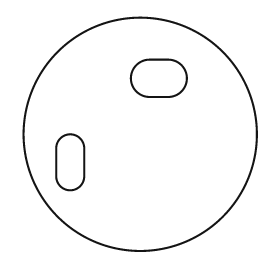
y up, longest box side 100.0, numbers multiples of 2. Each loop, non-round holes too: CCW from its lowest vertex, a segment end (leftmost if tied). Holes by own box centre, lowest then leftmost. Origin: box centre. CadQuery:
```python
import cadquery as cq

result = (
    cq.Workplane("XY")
    .moveTo(0.0, 0.0)
    .circle(50.0)
    .moveTo(-36.0, -18.0)
    .threePointArc((-30.0, -24.0), (-24.0, -18.0))
    .lineTo(-24.0, -6.0)
    .threePointArc((-30.0, 0.0), (-36.0, -6.0))
    .close()
    .moveTo(4.0, 16.0)
    .lineTo(12.0, 16.0)
    .threePointArc((20.0, 24.0), (12.0, 32.0))
    .lineTo(4.0, 32.0)
    .threePointArc((-4.0, 24.0), (4.0, 16.0))
    .close()
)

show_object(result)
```